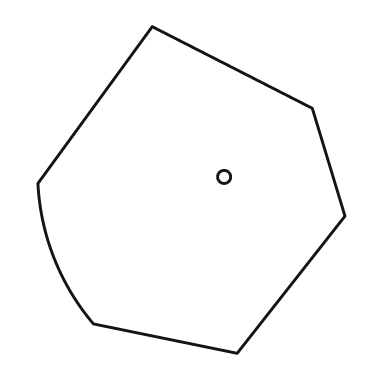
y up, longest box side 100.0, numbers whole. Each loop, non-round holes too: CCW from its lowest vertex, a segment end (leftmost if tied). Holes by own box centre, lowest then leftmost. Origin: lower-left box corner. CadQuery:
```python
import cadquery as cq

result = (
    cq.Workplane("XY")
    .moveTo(61.0, 0.0)
    .lineTo(94.0, 42.0)
    .lineTo(84.0, 75.0)
    .lineTo(35.0, 100.0)
    .lineTo(0.0, 52.0)
    .threePointArc((5.0, 29.0), (17.0, 9.0))
    .close()
    .moveTo(57.0, 54.0)
    .circle(2.0)
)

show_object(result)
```